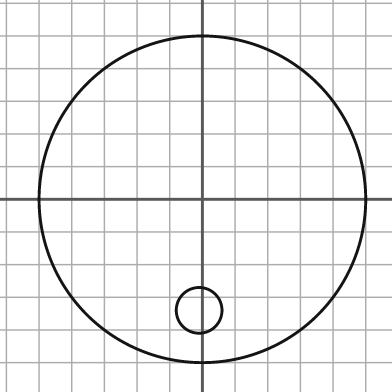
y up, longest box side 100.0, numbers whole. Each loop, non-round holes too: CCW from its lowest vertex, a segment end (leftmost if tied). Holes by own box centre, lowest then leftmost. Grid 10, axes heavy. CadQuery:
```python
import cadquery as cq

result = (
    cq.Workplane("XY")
    .moveTo(0.0, 0.0)
    .circle(50.0)
    .moveTo(-1.0, -34.0)
    .circle(7.0)
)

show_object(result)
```